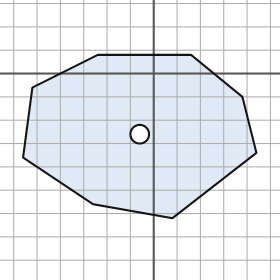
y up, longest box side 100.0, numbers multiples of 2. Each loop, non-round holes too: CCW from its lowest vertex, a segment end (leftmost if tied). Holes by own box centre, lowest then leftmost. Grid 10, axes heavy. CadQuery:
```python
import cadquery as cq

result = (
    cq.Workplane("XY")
    .moveTo(8.0, -62.0)
    .lineTo(44.0, -34.0)
    .lineTo(38.0, -10.0)
    .lineTo(16.0, 8.0)
    .lineTo(-24.0, 8.0)
    .lineTo(-52.0, -6.0)
    .lineTo(-56.0, -36.0)
    .lineTo(-26.0, -56.0)
    .close()
    .moveTo(-6.0, -26.0)
    .circle(4.0)
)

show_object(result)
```